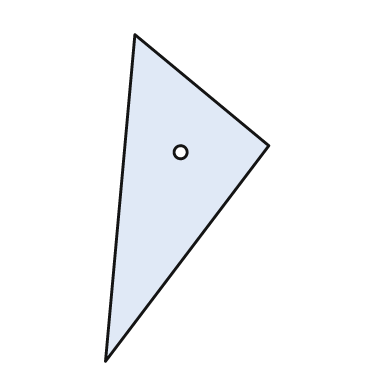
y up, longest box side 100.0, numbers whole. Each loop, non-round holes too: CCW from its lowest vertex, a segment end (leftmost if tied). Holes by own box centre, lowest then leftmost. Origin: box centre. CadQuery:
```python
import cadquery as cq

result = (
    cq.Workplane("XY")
    .moveTo(-25.0, -50.0)
    .lineTo(25.0, 16.0)
    .lineTo(-16.0, 50.0)
    .close()
    .moveTo(-2.0, 14.0)
    .circle(2.0)
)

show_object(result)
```